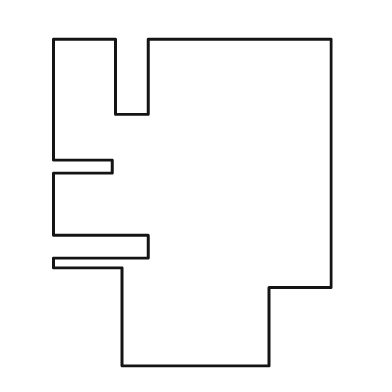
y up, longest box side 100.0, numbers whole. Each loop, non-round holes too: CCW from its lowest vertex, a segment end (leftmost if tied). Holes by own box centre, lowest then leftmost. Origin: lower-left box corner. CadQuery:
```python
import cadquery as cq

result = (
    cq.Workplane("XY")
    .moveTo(21.0, 0.0)
    .lineTo(66.0, 0.0)
    .lineTo(66.0, 24.0)
    .lineTo(85.0, 24.0)
    .lineTo(85.0, 100.0)
    .lineTo(29.0, 100.0)
    .lineTo(29.0, 77.0)
    .lineTo(19.0, 77.0)
    .lineTo(19.0, 100.0)
    .lineTo(0.0, 100.0)
    .lineTo(0.0, 63.0)
    .lineTo(18.0, 63.0)
    .lineTo(18.0, 59.0)
    .lineTo(0.0, 59.0)
    .lineTo(0.0, 40.0)
    .lineTo(29.0, 40.0)
    .lineTo(29.0, 33.0)
    .lineTo(0.0, 33.0)
    .lineTo(0.0, 30.0)
    .lineTo(21.0, 30.0)
    .close()
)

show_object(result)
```